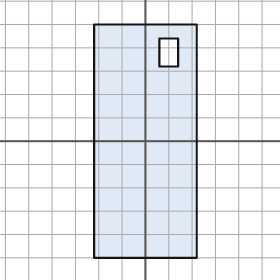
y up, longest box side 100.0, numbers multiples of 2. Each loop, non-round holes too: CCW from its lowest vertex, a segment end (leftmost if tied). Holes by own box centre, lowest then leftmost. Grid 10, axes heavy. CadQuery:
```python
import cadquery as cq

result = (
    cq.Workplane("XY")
    .moveTo(-22.0, -50.0)
    .lineTo(22.0, -50.0)
    .lineTo(22.0, 50.0)
    .lineTo(-22.0, 50.0)
    .close()
    .moveTo(6.0, 32.0)
    .lineTo(14.0, 32.0)
    .lineTo(14.0, 44.0)
    .lineTo(6.0, 44.0)
    .close()
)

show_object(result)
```